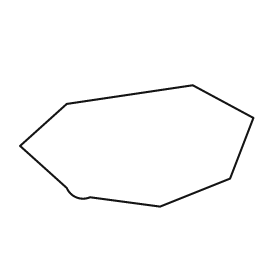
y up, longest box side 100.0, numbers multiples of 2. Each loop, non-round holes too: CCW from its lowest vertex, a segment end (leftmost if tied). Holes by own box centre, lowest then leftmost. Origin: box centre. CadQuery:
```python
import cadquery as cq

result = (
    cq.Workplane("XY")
    .moveTo(10.0, -26.0)
    .lineTo(40.0, -14.0)
    .lineTo(50.0, 12.0)
    .lineTo(24.0, 26.0)
    .lineTo(-30.0, 18.0)
    .lineTo(-50.0, 0.0)
    .lineTo(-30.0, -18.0)
    .threePointArc((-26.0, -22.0), (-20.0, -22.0))
    .close()
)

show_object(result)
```